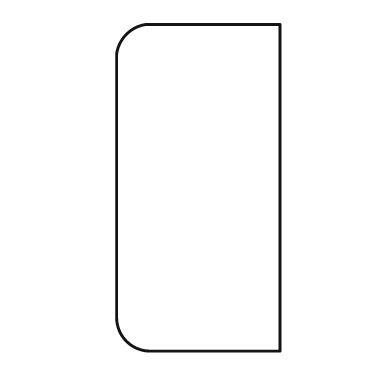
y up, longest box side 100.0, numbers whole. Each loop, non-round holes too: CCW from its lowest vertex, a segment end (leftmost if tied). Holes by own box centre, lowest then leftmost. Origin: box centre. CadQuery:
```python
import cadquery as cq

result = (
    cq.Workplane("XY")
    .moveTo(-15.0, -50.0)
    .lineTo(25.0, -50.0)
    .lineTo(25.0, 50.0)
    .lineTo(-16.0, 50.0)
    .threePointArc((-22.0, 47.0), (-25.0, 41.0))
    .lineTo(-25.0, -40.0)
    .threePointArc((-22.0, -47.0), (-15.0, -50.0))
    .close()
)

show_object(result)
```